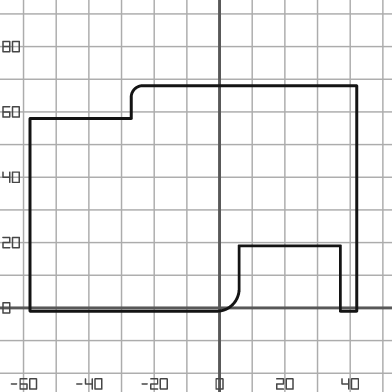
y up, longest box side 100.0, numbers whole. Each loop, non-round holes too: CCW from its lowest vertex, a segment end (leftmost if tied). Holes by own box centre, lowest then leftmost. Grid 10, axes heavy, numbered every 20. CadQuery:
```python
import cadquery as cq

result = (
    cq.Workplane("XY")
    .moveTo(-58.0, -1.0)
    .lineTo(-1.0, -1.0)
    .threePointArc((4.0, 1.0), (6.0, 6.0))
    .lineTo(6.0, 19.0)
    .lineTo(37.0, 19.0)
    .lineTo(37.0, -1.0)
    .lineTo(42.0, -1.0)
    .lineTo(42.0, 68.0)
    .lineTo(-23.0, 68.0)
    .threePointArc((-26.0, 67.0), (-27.0, 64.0))
    .lineTo(-27.0, 58.0)
    .lineTo(-58.0, 58.0)
    .close()
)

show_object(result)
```